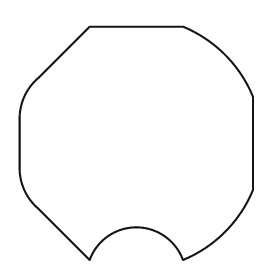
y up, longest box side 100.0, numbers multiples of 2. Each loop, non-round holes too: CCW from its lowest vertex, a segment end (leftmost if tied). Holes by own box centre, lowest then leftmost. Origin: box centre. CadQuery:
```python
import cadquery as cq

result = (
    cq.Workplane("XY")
    .moveTo(-20.0, -50.0)
    .threePointArc((0.0, -36.0), (20.0, -50.0))
    .threePointArc((38.0, -38.0), (50.0, -20.0))
    .lineTo(50.0, 20.0)
    .threePointArc((38.0, 38.0), (20.0, 50.0))
    .lineTo(-20.0, 50.0)
    .lineTo(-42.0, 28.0)
    .threePointArc((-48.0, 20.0), (-50.0, 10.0))
    .lineTo(-50.0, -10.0)
    .threePointArc((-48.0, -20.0), (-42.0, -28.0))
    .close()
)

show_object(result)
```